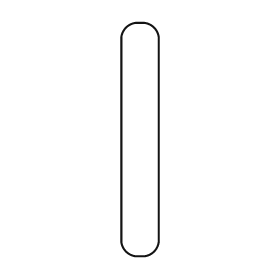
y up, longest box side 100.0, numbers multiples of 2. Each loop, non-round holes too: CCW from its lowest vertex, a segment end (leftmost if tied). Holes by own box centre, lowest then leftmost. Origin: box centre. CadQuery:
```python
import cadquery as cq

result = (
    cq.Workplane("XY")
    .moveTo(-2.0, -50.0)
    .lineTo(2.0, -50.0)
    .threePointArc((6.0, -48.0), (8.0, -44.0))
    .lineTo(8.0, 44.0)
    .threePointArc((6.0, 48.0), (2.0, 50.0))
    .lineTo(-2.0, 50.0)
    .threePointArc((-6.0, 48.0), (-8.0, 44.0))
    .lineTo(-8.0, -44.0)
    .threePointArc((-6.0, -48.0), (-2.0, -50.0))
    .close()
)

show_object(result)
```